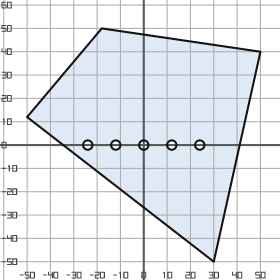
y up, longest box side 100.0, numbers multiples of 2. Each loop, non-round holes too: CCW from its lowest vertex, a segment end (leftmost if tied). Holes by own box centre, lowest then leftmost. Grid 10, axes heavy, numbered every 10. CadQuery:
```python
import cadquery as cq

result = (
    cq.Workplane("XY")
    .moveTo(30.0, -50.0)
    .lineTo(50.0, 40.0)
    .lineTo(-18.0, 50.0)
    .lineTo(-50.0, 12.0)
    .close()
    .moveTo(-24.0, 0.0)
    .circle(2.0)
    .moveTo(-12.0, 0.0)
    .circle(2.0)
    .moveTo(0.0, 0.0)
    .circle(2.0)
    .moveTo(12.0, 0.0)
    .circle(2.0)
    .moveTo(24.0, 0.0)
    .circle(2.0)
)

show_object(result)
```